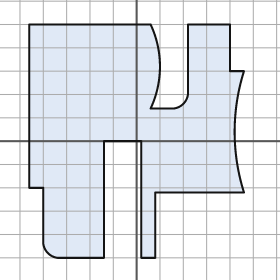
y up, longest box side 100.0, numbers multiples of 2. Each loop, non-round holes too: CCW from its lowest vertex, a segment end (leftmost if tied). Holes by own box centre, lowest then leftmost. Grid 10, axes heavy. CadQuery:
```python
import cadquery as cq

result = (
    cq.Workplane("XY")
    .moveTo(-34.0, -50.0)
    .lineTo(-14.0, -50.0)
    .lineTo(-14.0, 0.0)
    .lineTo(2.0, 0.0)
    .lineTo(2.0, -50.0)
    .lineTo(8.0, -50.0)
    .lineTo(8.0, -22.0)
    .lineTo(46.0, -22.0)
    .threePointArc((42.0, 4.0), (46.0, 30.0))
    .lineTo(40.0, 30.0)
    .lineTo(40.0, 50.0)
    .lineTo(22.0, 50.0)
    .lineTo(22.0, 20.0)
    .threePointArc((20.0, 16.0), (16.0, 14.0))
    .lineTo(6.0, 14.0)
    .threePointArc((10.0, 32.0), (6.0, 50.0))
    .lineTo(-46.0, 50.0)
    .lineTo(-46.0, -20.0)
    .lineTo(-40.0, -20.0)
    .lineTo(-40.0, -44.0)
    .threePointArc((-38.0, -48.0), (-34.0, -50.0))
    .close()
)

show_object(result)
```